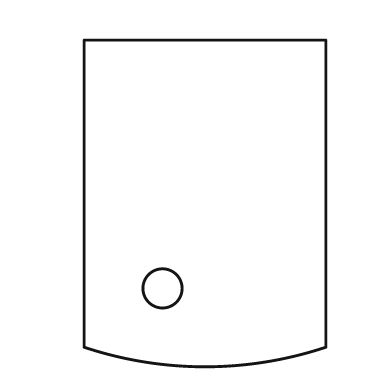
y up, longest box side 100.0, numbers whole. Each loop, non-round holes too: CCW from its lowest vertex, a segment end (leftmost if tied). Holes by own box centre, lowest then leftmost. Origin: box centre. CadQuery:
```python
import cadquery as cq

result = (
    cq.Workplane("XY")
    .moveTo(-37.0, -44.0)
    .threePointArc((0.0, -50.0), (37.0, -44.0))
    .lineTo(37.0, 50.0)
    .lineTo(-37.0, 50.0)
    .close()
    .moveTo(-13.0, -26.0)
    .circle(6.0)
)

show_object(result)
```